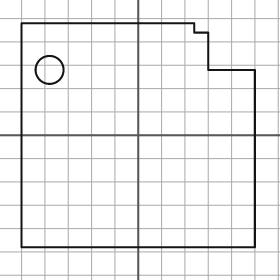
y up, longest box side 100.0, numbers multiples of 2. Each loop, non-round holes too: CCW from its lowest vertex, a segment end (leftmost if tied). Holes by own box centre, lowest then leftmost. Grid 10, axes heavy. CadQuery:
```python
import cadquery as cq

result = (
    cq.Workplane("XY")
    .moveTo(-50.0, -48.0)
    .lineTo(50.0, -48.0)
    .lineTo(50.0, 28.0)
    .lineTo(30.0, 28.0)
    .lineTo(30.0, 44.0)
    .lineTo(24.0, 44.0)
    .lineTo(24.0, 48.0)
    .lineTo(-50.0, 48.0)
    .close()
    .moveTo(-38.0, 28.0)
    .circle(6.0)
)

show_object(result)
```